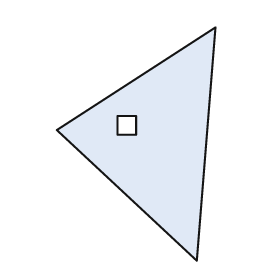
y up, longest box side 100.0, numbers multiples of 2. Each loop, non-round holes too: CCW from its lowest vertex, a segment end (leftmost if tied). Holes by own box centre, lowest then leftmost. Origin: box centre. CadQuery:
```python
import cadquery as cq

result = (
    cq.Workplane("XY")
    .moveTo(26.0, -50.0)
    .lineTo(34.0, 50.0)
    .lineTo(-34.0, 6.0)
    .close()
    .moveTo(-8.0, 4.0)
    .lineTo(0.0, 4.0)
    .lineTo(0.0, 12.0)
    .lineTo(-8.0, 12.0)
    .close()
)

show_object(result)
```